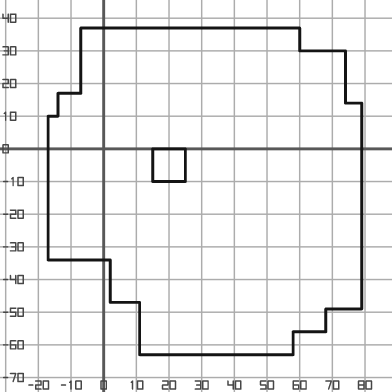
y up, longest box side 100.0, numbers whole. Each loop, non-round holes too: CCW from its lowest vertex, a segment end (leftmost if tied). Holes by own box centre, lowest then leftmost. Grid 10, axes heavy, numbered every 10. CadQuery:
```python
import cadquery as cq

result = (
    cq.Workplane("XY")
    .moveTo(11.0, -63.0)
    .lineTo(58.0, -63.0)
    .lineTo(58.0, -56.0)
    .lineTo(68.0, -56.0)
    .lineTo(68.0, -49.0)
    .lineTo(79.0, -49.0)
    .lineTo(79.0, 14.0)
    .lineTo(74.0, 14.0)
    .lineTo(74.0, 30.0)
    .lineTo(60.0, 30.0)
    .lineTo(60.0, 37.0)
    .lineTo(-7.0, 37.0)
    .lineTo(-7.0, 17.0)
    .lineTo(-14.0, 17.0)
    .lineTo(-14.0, 10.0)
    .lineTo(-17.0, 10.0)
    .lineTo(-17.0, -34.0)
    .lineTo(2.0, -34.0)
    .lineTo(2.0, -47.0)
    .lineTo(11.0, -47.0)
    .close()
    .moveTo(15.0, -10.0)
    .lineTo(25.0, -10.0)
    .lineTo(25.0, 0.0)
    .lineTo(15.0, 0.0)
    .close()
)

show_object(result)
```